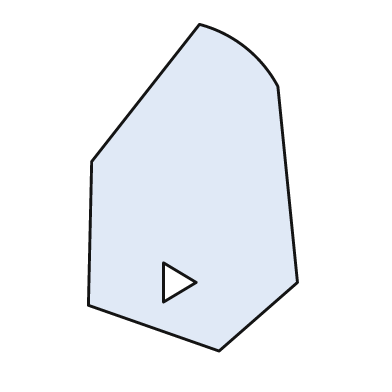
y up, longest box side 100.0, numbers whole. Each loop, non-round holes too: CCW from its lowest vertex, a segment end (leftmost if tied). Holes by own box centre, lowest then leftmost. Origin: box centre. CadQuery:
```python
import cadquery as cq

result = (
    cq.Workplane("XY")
    .moveTo(8.0, -50.0)
    .lineTo(32.0, -29.0)
    .lineTo(26.0, 31.0)
    .threePointArc((16.0, 43.0), (2.0, 50.0))
    .lineTo(-31.0, 8.0)
    .lineTo(-32.0, -36.0)
    .close()
    .moveTo(-9.0, -35.0)
    .lineTo(1.0, -29.0)
    .lineTo(-9.0, -23.0)
    .close()
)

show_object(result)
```